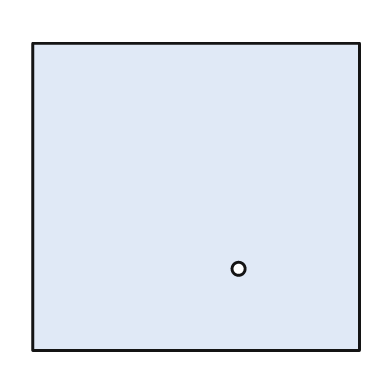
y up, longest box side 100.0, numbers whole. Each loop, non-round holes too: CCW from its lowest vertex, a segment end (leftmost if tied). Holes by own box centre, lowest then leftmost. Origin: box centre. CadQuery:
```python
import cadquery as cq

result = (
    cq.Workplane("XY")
    .moveTo(-50.0, -47.0)
    .lineTo(50.0, -47.0)
    .lineTo(50.0, 47.0)
    .lineTo(-50.0, 47.0)
    .close()
    .moveTo(13.0, -22.0)
    .circle(2.0)
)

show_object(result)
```